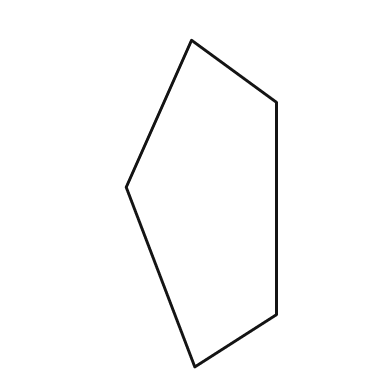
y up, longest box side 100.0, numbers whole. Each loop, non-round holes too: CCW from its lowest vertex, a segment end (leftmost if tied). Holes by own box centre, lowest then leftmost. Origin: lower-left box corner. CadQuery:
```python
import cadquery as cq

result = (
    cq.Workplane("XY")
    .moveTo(21.0, 0.0)
    .lineTo(46.0, 16.0)
    .lineTo(46.0, 81.0)
    .lineTo(20.0, 100.0)
    .lineTo(0.0, 55.0)
    .close()
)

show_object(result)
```